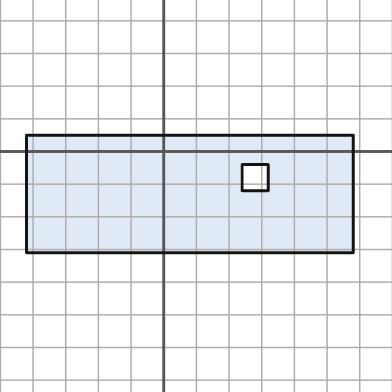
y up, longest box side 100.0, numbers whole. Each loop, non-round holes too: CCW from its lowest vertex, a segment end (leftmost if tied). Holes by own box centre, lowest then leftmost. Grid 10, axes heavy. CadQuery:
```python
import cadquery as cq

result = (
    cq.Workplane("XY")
    .moveTo(-42.0, -31.0)
    .lineTo(58.0, -31.0)
    .lineTo(58.0, 5.0)
    .lineTo(-42.0, 5.0)
    .close()
    .moveTo(24.0, -12.0)
    .lineTo(32.0, -12.0)
    .lineTo(32.0, -4.0)
    .lineTo(24.0, -4.0)
    .close()
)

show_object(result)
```